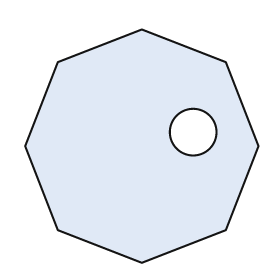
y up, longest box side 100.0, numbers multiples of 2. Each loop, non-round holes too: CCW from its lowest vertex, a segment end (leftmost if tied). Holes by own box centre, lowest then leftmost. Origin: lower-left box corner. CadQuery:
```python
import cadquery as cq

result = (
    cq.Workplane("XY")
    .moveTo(50.0, 0.0)
    .lineTo(86.0, 14.0)
    .lineTo(100.0, 50.0)
    .lineTo(86.0, 86.0)
    .lineTo(50.0, 100.0)
    .lineTo(14.0, 86.0)
    .lineTo(0.0, 50.0)
    .lineTo(14.0, 14.0)
    .close()
    .moveTo(72.0, 56.0)
    .circle(10.0)
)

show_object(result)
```